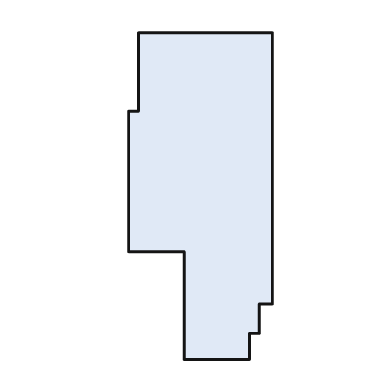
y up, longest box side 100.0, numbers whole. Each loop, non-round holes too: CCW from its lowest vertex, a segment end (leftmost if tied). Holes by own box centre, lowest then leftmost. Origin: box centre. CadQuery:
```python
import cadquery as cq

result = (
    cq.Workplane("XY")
    .moveTo(-5.0, -50.0)
    .lineTo(15.0, -50.0)
    .lineTo(15.0, -42.0)
    .lineTo(18.0, -42.0)
    .lineTo(18.0, -33.0)
    .lineTo(22.0, -33.0)
    .lineTo(22.0, 50.0)
    .lineTo(-19.0, 50.0)
    .lineTo(-19.0, 26.0)
    .lineTo(-22.0, 26.0)
    .lineTo(-22.0, -17.0)
    .lineTo(-5.0, -17.0)
    .close()
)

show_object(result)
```